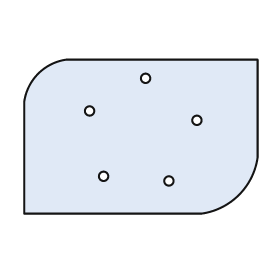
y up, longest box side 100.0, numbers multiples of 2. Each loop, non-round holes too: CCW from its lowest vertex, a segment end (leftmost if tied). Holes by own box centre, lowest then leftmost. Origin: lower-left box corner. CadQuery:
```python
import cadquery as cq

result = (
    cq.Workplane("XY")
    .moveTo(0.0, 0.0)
    .lineTo(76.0, 0.0)
    .threePointArc((92.0, 8.0), (100.0, 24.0))
    .lineTo(100.0, 66.0)
    .lineTo(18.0, 66.0)
    .threePointArc((6.0, 60.0), (0.0, 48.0))
    .close()
    .moveTo(62.0, 14.0)
    .circle(2.0)
    .moveTo(34.0, 16.0)
    .circle(2.0)
    .moveTo(74.0, 40.0)
    .circle(2.0)
    .moveTo(28.0, 44.0)
    .circle(2.0)
    .moveTo(52.0, 58.0)
    .circle(2.0)
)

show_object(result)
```